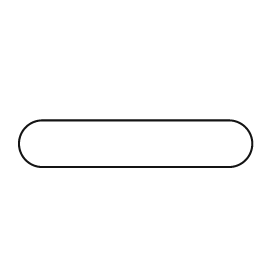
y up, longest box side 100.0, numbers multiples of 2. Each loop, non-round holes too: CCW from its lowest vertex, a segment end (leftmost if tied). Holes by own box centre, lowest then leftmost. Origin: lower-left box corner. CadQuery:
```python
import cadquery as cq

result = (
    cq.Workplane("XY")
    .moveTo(10.0, 0.0)
    .lineTo(90.0, 0.0)
    .threePointArc((100.0, 10.0), (90.0, 20.0))
    .lineTo(10.0, 20.0)
    .threePointArc((0.0, 10.0), (10.0, 0.0))
    .close()
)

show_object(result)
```